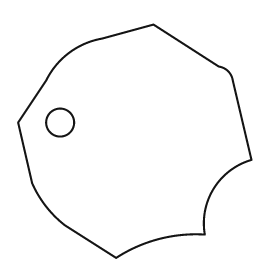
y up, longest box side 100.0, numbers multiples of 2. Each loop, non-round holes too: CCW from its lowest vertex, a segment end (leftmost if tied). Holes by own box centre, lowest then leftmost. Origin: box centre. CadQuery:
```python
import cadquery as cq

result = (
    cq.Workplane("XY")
    .moveTo(-8.0, -50.0)
    .threePointArc((10.0, -42.0), (30.0, -40.0))
    .threePointArc((34.0, -20.0), (50.0, -8.0))
    .lineTo(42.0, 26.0)
    .threePointArc((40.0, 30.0), (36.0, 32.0))
    .lineTo(8.0, 50.0)
    .lineTo(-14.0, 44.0)
    .threePointArc((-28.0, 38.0), (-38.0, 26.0))
    .lineTo(-50.0, 8.0)
    .lineTo(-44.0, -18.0)
    .threePointArc((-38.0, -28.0), (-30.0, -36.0))
    .close()
    .moveTo(-32.0, 8.0)
    .circle(6.0)
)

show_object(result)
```